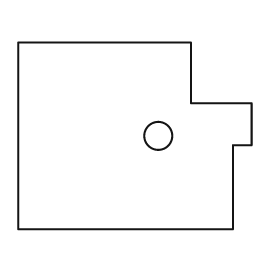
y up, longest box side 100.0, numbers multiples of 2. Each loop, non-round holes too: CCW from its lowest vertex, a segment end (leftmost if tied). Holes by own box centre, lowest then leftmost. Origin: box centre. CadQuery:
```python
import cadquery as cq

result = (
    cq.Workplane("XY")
    .moveTo(-50.0, -40.0)
    .lineTo(42.0, -40.0)
    .lineTo(42.0, -4.0)
    .lineTo(50.0, -4.0)
    .lineTo(50.0, 14.0)
    .lineTo(24.0, 14.0)
    .lineTo(24.0, 40.0)
    .lineTo(-50.0, 40.0)
    .close()
    .moveTo(10.0, 0.0)
    .circle(6.0)
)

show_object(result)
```